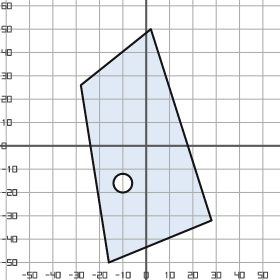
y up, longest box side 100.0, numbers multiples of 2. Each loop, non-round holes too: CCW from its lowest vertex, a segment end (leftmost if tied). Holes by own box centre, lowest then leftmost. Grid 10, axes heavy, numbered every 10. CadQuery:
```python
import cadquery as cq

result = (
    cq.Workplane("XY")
    .moveTo(-16.0, -50.0)
    .lineTo(28.0, -32.0)
    .lineTo(2.0, 50.0)
    .lineTo(-28.0, 26.0)
    .close()
    .moveTo(-10.0, -16.0)
    .circle(4.0)
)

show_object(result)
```